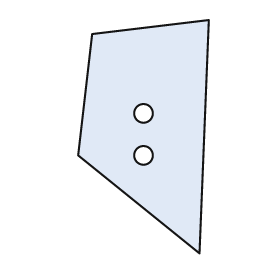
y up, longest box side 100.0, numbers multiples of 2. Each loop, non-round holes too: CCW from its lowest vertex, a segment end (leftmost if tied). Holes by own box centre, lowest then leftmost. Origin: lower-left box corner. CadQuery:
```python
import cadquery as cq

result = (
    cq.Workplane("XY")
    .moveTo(52.0, 0.0)
    .lineTo(56.0, 100.0)
    .lineTo(6.0, 94.0)
    .lineTo(0.0, 42.0)
    .close()
    .moveTo(28.0, 42.0)
    .circle(4.0)
    .moveTo(28.0, 60.0)
    .circle(4.0)
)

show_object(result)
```